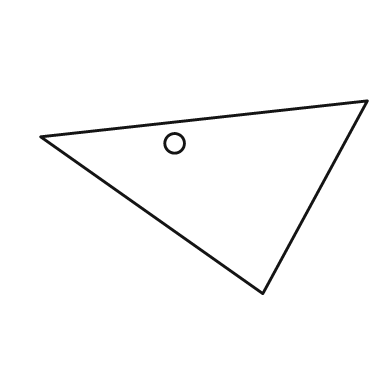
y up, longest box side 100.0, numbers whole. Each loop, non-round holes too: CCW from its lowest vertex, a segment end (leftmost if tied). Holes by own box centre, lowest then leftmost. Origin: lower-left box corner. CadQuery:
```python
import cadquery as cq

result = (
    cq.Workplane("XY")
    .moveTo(68.0, 0.0)
    .lineTo(100.0, 59.0)
    .lineTo(0.0, 48.0)
    .close()
    .moveTo(41.0, 46.0)
    .circle(3.0)
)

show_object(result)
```